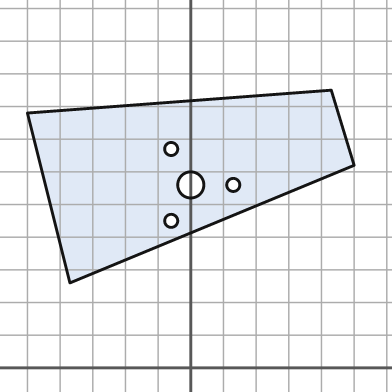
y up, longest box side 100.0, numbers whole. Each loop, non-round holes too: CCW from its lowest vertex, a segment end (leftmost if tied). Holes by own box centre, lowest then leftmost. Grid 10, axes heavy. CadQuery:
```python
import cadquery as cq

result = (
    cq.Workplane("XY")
    .moveTo(-37.0, 26.0)
    .lineTo(50.0, 62.0)
    .lineTo(43.0, 85.0)
    .lineTo(-50.0, 78.0)
    .close()
    .moveTo(-6.0, 45.0)
    .circle(2.0)
    .moveTo(0.0, 56.0)
    .circle(4.0)
    .moveTo(13.0, 56.0)
    .circle(2.0)
    .moveTo(-6.0, 67.0)
    .circle(2.0)
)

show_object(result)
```